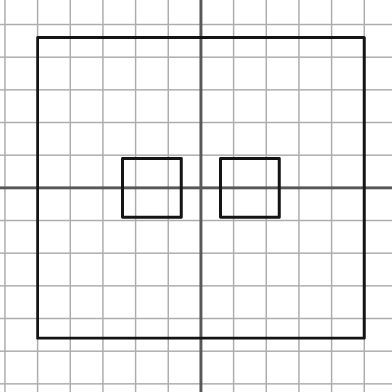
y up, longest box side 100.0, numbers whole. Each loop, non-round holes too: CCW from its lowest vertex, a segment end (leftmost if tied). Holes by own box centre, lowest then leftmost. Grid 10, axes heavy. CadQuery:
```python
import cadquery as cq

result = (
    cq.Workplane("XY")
    .moveTo(-50.0, -46.0)
    .lineTo(50.0, -46.0)
    .lineTo(50.0, 46.0)
    .lineTo(-50.0, 46.0)
    .close()
    .moveTo(-24.0, -9.0)
    .lineTo(-6.0, -9.0)
    .lineTo(-6.0, 9.0)
    .lineTo(-24.0, 9.0)
    .close()
    .moveTo(6.0, -9.0)
    .lineTo(24.0, -9.0)
    .lineTo(24.0, 9.0)
    .lineTo(6.0, 9.0)
    .close()
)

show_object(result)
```